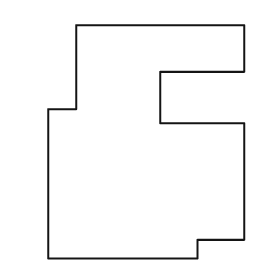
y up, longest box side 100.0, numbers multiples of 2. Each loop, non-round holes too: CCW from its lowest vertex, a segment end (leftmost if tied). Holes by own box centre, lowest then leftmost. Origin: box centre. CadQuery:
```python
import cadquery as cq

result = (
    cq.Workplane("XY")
    .moveTo(-42.0, -50.0)
    .lineTo(22.0, -50.0)
    .lineTo(22.0, -42.0)
    .lineTo(42.0, -42.0)
    .lineTo(42.0, 8.0)
    .lineTo(6.0, 8.0)
    .lineTo(6.0, 30.0)
    .lineTo(42.0, 30.0)
    .lineTo(42.0, 50.0)
    .lineTo(-30.0, 50.0)
    .lineTo(-30.0, 14.0)
    .lineTo(-42.0, 14.0)
    .close()
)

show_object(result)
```